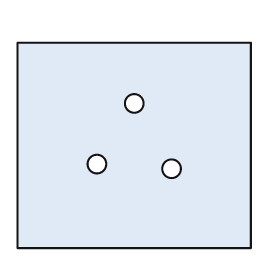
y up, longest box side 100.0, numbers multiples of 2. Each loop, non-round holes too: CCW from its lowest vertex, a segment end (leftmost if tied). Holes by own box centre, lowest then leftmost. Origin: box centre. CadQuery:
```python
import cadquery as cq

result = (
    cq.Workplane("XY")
    .moveTo(-50.0, -44.0)
    .lineTo(50.0, -44.0)
    .lineTo(50.0, 44.0)
    .lineTo(-50.0, 44.0)
    .close()
    .moveTo(16.0, -10.0)
    .circle(4.0)
    .moveTo(-16.0, -8.0)
    .circle(4.0)
    .moveTo(0.0, 18.0)
    .circle(4.0)
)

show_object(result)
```